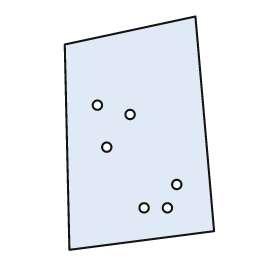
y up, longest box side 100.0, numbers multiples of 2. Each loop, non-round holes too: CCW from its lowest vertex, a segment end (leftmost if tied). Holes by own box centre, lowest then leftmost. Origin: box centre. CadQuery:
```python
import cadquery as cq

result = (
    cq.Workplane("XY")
    .moveTo(-30.0, -50.0)
    .lineTo(32.0, -42.0)
    .lineTo(24.0, 50.0)
    .lineTo(-32.0, 38.0)
    .close()
    .moveTo(2.0, -32.0)
    .circle(2.0)
    .moveTo(12.0, -32.0)
    .circle(2.0)
    .moveTo(16.0, -22.0)
    .circle(2.0)
    .moveTo(-14.0, -6.0)
    .circle(2.0)
    .moveTo(-4.0, 8.0)
    .circle(2.0)
    .moveTo(-18.0, 12.0)
    .circle(2.0)
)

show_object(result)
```